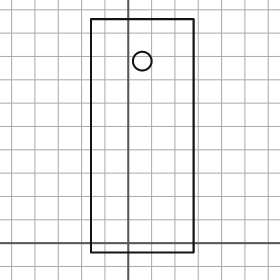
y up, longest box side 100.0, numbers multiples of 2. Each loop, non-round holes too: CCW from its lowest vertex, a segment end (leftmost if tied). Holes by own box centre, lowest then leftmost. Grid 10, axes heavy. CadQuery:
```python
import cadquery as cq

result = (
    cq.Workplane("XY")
    .moveTo(-16.0, -4.0)
    .lineTo(28.0, -4.0)
    .lineTo(28.0, 96.0)
    .lineTo(-16.0, 96.0)
    .close()
    .moveTo(6.0, 78.0)
    .circle(4.0)
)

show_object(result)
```